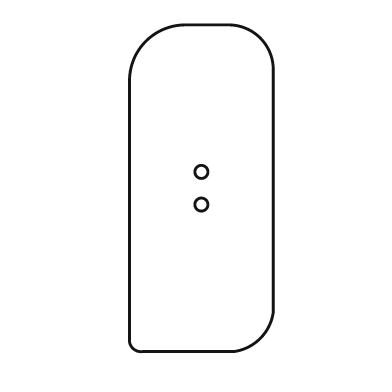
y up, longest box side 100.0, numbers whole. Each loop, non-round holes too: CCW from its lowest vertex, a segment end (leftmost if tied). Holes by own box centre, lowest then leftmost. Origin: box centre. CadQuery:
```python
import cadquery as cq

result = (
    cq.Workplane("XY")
    .moveTo(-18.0, -50.0)
    .lineTo(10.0, -50.0)
    .threePointArc((18.0, -46.0), (22.0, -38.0))
    .lineTo(22.0, 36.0)
    .threePointArc((18.0, 46.0), (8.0, 50.0))
    .lineTo(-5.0, 50.0)
    .threePointArc((-17.0, 45.0), (-22.0, 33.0))
    .lineTo(-22.0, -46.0)
    .threePointArc((-21.0, -49.0), (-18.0, -50.0))
    .close()
    .moveTo(0.0, -5.0)
    .circle(2.0)
    .moveTo(0.0, 5.0)
    .circle(2.0)
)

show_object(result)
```